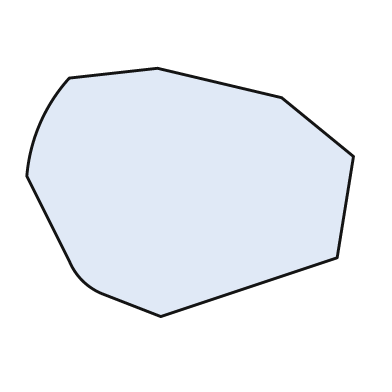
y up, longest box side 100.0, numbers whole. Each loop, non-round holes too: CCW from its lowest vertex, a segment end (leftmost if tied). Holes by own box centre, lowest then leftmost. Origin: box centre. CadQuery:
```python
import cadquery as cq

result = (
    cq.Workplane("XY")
    .moveTo(-9.0, -38.0)
    .lineTo(45.0, -20.0)
    .lineTo(50.0, 11.0)
    .lineTo(28.0, 29.0)
    .lineTo(-10.0, 38.0)
    .lineTo(-37.0, 35.0)
    .threePointArc((-46.0, 21.0), (-50.0, 5.0))
    .lineTo(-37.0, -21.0)
    .threePointArc((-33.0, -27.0), (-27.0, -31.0))
    .close()
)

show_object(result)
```